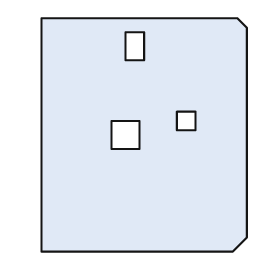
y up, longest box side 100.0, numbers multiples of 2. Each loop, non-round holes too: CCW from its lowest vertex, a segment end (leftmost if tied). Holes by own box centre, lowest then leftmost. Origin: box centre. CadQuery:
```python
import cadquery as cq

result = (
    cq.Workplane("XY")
    .moveTo(-44.0, -50.0)
    .lineTo(38.0, -50.0)
    .lineTo(44.0, -44.0)
    .lineTo(44.0, 46.0)
    .lineTo(40.0, 50.0)
    .lineTo(-44.0, 50.0)
    .close()
    .moveTo(-14.0, -6.0)
    .lineTo(-2.0, -6.0)
    .lineTo(-2.0, 6.0)
    .lineTo(-14.0, 6.0)
    .close()
    .moveTo(14.0, 2.0)
    .lineTo(22.0, 2.0)
    .lineTo(22.0, 10.0)
    .lineTo(14.0, 10.0)
    .close()
    .moveTo(-8.0, 32.0)
    .lineTo(0.0, 32.0)
    .lineTo(0.0, 44.0)
    .lineTo(-8.0, 44.0)
    .close()
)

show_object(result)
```